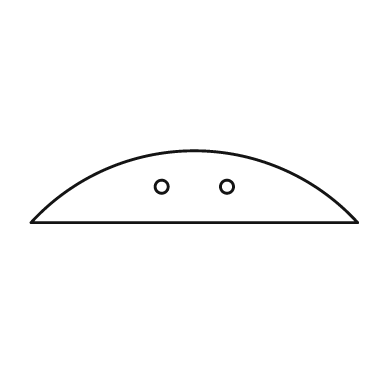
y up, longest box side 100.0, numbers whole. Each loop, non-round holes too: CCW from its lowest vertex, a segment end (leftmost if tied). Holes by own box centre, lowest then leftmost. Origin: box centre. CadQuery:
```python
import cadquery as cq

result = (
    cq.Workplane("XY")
    .moveTo(-50.0, -11.0)
    .lineTo(50.0, -11.0)
    .threePointArc((0.0, 11.0), (-50.0, -11.0))
    .close()
    .moveTo(-10.0, 0.0)
    .circle(2.0)
    .moveTo(10.0, 0.0)
    .circle(2.0)
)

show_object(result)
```